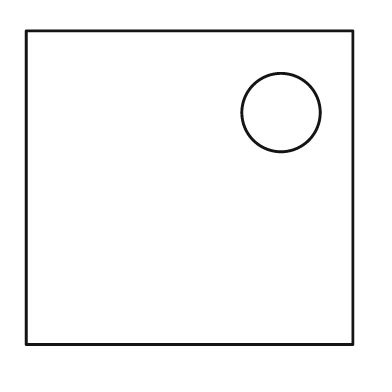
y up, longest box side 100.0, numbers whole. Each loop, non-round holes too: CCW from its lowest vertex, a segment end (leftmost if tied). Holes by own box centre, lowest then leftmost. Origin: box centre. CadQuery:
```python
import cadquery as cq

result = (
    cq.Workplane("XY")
    .moveTo(-50.0, -48.0)
    .lineTo(50.0, -48.0)
    .lineTo(50.0, 48.0)
    .lineTo(-50.0, 48.0)
    .close()
    .moveTo(28.0, 23.0)
    .circle(12.0)
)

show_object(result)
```